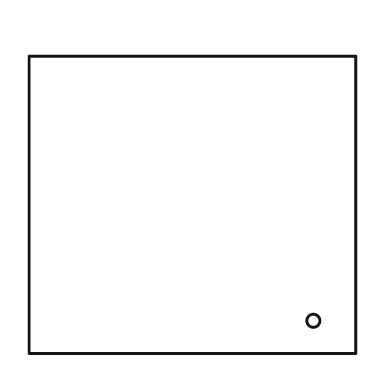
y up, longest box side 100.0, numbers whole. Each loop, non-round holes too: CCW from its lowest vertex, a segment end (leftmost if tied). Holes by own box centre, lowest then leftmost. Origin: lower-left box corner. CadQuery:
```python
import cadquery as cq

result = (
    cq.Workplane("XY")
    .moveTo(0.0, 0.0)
    .lineTo(100.0, 0.0)
    .lineTo(100.0, 91.0)
    .lineTo(0.0, 91.0)
    .close()
    .moveTo(87.0, 10.0)
    .circle(2.0)
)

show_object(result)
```